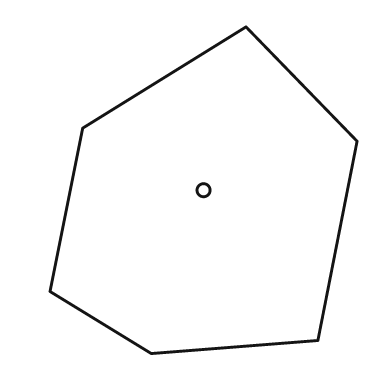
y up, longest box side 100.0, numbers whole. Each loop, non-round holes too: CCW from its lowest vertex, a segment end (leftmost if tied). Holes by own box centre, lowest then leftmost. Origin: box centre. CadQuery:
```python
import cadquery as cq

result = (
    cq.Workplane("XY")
    .moveTo(-16.0, -50.0)
    .lineTo(35.0, -46.0)
    .lineTo(47.0, 15.0)
    .lineTo(13.0, 50.0)
    .lineTo(-37.0, 19.0)
    .lineTo(-47.0, -31.0)
    .close()
    .moveTo(0.0, 0.0)
    .circle(2.0)
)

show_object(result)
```